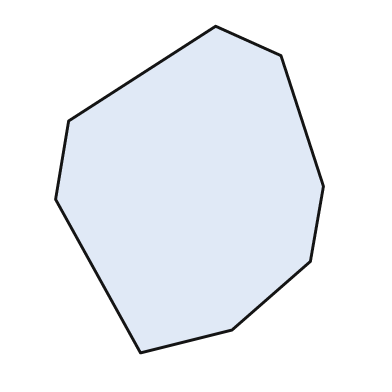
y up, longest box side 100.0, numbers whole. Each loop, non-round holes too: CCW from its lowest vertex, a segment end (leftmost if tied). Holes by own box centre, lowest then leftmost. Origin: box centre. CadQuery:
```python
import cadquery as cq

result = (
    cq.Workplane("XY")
    .moveTo(-15.0, -50.0)
    .lineTo(13.0, -43.0)
    .lineTo(37.0, -22.0)
    .lineTo(41.0, 1.0)
    .lineTo(28.0, 41.0)
    .lineTo(8.0, 50.0)
    .lineTo(-37.0, 21.0)
    .lineTo(-41.0, -3.0)
    .close()
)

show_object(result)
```